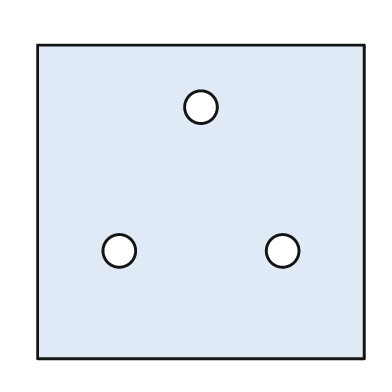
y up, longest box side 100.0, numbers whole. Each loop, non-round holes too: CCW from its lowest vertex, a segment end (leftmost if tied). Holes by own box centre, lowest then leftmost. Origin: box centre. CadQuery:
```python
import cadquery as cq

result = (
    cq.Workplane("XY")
    .moveTo(-50.0, -48.0)
    .lineTo(50.0, -48.0)
    .lineTo(50.0, 48.0)
    .lineTo(-50.0, 48.0)
    .close()
    .moveTo(-25.0, -15.0)
    .circle(5.0)
    .moveTo(25.0, -15.0)
    .circle(5.0)
    .moveTo(0.0, 29.0)
    .circle(5.0)
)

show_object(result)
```